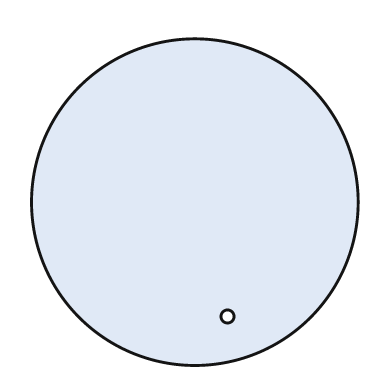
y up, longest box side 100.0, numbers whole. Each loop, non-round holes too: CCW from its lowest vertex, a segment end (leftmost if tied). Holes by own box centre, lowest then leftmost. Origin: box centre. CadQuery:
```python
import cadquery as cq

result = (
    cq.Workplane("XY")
    .moveTo(0.0, 0.0)
    .circle(50.0)
    .moveTo(10.0, -35.0)
    .circle(2.0)
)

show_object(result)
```